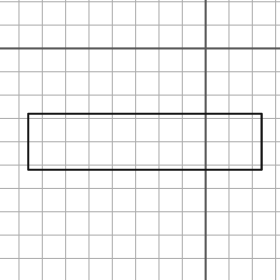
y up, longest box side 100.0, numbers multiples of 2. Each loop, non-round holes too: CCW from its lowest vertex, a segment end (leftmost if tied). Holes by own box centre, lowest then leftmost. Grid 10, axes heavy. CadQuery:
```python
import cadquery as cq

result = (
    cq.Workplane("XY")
    .moveTo(-76.0, -52.0)
    .lineTo(24.0, -52.0)
    .lineTo(24.0, -28.0)
    .lineTo(-76.0, -28.0)
    .close()
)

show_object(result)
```